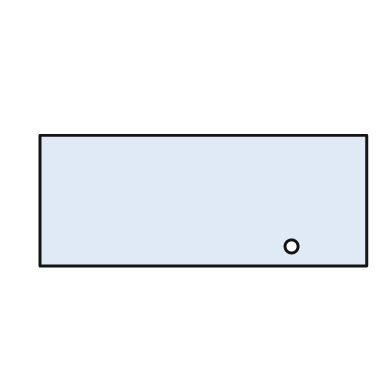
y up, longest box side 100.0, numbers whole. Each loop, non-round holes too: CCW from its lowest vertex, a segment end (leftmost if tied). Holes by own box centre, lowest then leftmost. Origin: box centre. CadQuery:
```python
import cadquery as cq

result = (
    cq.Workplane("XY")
    .moveTo(-50.0, -20.0)
    .lineTo(50.0, -20.0)
    .lineTo(50.0, 20.0)
    .lineTo(-50.0, 20.0)
    .close()
    .moveTo(27.0, -14.0)
    .circle(2.0)
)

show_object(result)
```